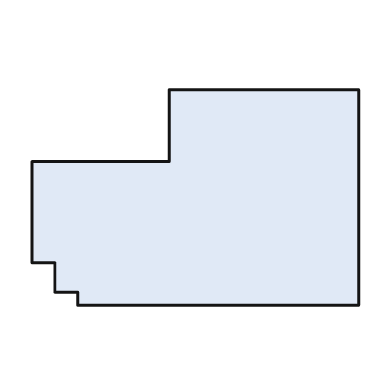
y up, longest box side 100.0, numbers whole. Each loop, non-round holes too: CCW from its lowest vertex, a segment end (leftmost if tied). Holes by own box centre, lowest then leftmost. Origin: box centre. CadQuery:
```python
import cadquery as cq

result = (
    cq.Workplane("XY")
    .moveTo(-36.0, -33.0)
    .lineTo(50.0, -33.0)
    .lineTo(50.0, 33.0)
    .lineTo(-8.0, 33.0)
    .lineTo(-8.0, 11.0)
    .lineTo(-50.0, 11.0)
    .lineTo(-50.0, -20.0)
    .lineTo(-43.0, -20.0)
    .lineTo(-43.0, -29.0)
    .lineTo(-36.0, -29.0)
    .close()
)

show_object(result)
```